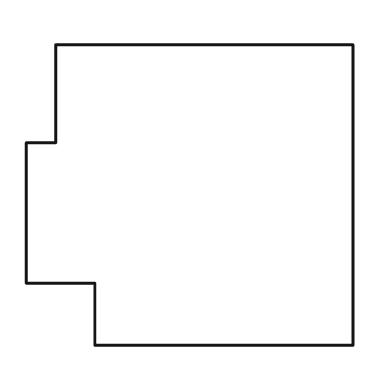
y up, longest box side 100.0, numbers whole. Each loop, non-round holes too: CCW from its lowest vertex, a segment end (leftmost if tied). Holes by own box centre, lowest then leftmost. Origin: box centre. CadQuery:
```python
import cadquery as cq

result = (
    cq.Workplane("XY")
    .moveTo(-29.0, -46.0)
    .lineTo(50.0, -46.0)
    .lineTo(50.0, 46.0)
    .lineTo(-41.0, 46.0)
    .lineTo(-41.0, 16.0)
    .lineTo(-50.0, 16.0)
    .lineTo(-50.0, -27.0)
    .lineTo(-29.0, -27.0)
    .close()
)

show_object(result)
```